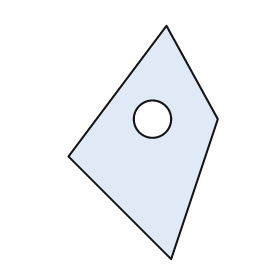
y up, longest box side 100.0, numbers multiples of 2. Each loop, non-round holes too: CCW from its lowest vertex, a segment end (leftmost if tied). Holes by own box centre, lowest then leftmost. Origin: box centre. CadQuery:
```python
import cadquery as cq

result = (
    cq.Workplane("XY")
    .moveTo(12.0, -50.0)
    .lineTo(32.0, 10.0)
    .lineTo(10.0, 50.0)
    .lineTo(-32.0, -6.0)
    .close()
    .moveTo(4.0, 10.0)
    .circle(8.0)
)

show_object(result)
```